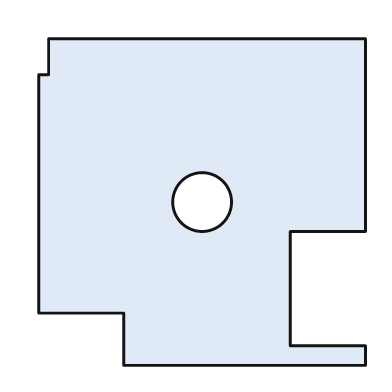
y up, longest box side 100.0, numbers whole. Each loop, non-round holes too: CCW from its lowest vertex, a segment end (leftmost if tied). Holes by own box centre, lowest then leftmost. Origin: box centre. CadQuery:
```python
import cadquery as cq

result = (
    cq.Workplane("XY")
    .moveTo(-24.0, -50.0)
    .lineTo(50.0, -50.0)
    .lineTo(50.0, -44.0)
    .lineTo(27.0, -44.0)
    .lineTo(27.0, -9.0)
    .lineTo(50.0, -9.0)
    .lineTo(50.0, 50.0)
    .lineTo(-47.0, 50.0)
    .lineTo(-47.0, 39.0)
    .lineTo(-50.0, 39.0)
    .lineTo(-50.0, -34.0)
    .lineTo(-24.0, -34.0)
    .close()
    .moveTo(0.0, 0.0)
    .circle(9.0)
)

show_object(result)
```